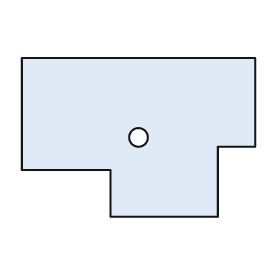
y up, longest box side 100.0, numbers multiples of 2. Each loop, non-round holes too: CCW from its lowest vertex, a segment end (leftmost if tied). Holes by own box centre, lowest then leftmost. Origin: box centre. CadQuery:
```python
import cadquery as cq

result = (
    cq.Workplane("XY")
    .moveTo(-12.0, -34.0)
    .lineTo(34.0, -34.0)
    .lineTo(34.0, -4.0)
    .lineTo(50.0, -4.0)
    .lineTo(50.0, 34.0)
    .lineTo(-50.0, 34.0)
    .lineTo(-50.0, -14.0)
    .lineTo(-12.0, -14.0)
    .close()
    .moveTo(0.0, 0.0)
    .circle(4.0)
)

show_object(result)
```